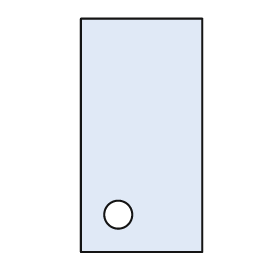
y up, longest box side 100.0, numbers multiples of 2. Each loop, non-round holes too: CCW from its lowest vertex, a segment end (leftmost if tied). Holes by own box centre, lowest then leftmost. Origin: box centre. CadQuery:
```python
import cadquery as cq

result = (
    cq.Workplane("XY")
    .moveTo(-26.0, -50.0)
    .lineTo(26.0, -50.0)
    .lineTo(26.0, 50.0)
    .lineTo(-26.0, 50.0)
    .close()
    .moveTo(-10.0, -34.0)
    .circle(6.0)
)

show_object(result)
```